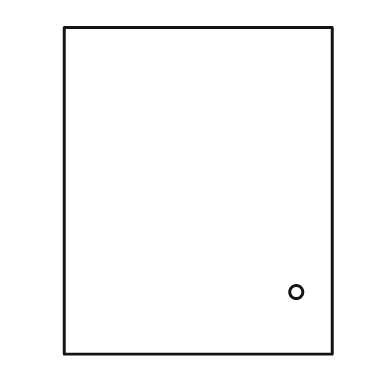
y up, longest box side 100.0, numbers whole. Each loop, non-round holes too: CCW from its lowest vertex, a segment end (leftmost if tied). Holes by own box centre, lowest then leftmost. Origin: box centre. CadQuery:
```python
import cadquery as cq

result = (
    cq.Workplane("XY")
    .moveTo(-41.0, -50.0)
    .lineTo(41.0, -50.0)
    .lineTo(41.0, 50.0)
    .lineTo(-41.0, 50.0)
    .close()
    .moveTo(30.0, -31.0)
    .circle(2.0)
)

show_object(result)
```